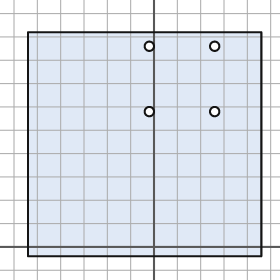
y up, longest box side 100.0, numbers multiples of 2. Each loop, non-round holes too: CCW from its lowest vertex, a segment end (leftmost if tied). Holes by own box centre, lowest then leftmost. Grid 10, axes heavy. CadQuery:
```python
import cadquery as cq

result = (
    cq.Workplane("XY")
    .moveTo(-54.0, -4.0)
    .lineTo(46.0, -4.0)
    .lineTo(46.0, 92.0)
    .lineTo(-54.0, 92.0)
    .close()
    .moveTo(-2.0, 58.0)
    .circle(2.0)
    .moveTo(26.0, 58.0)
    .circle(2.0)
    .moveTo(-2.0, 86.0)
    .circle(2.0)
    .moveTo(26.0, 86.0)
    .circle(2.0)
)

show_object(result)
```